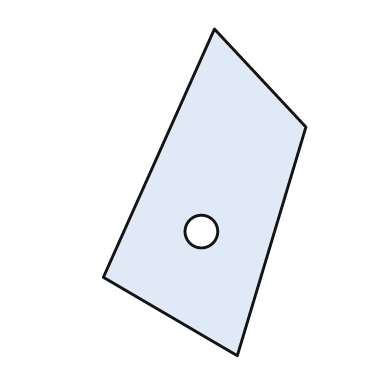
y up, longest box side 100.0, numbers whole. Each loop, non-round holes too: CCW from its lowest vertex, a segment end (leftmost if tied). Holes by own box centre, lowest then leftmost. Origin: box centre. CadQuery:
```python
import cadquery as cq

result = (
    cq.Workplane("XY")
    .moveTo(10.0, -50.0)
    .lineTo(31.0, 20.0)
    .lineTo(3.0, 50.0)
    .lineTo(-31.0, -26.0)
    .close()
    .moveTo(-1.0, -12.0)
    .circle(5.0)
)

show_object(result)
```